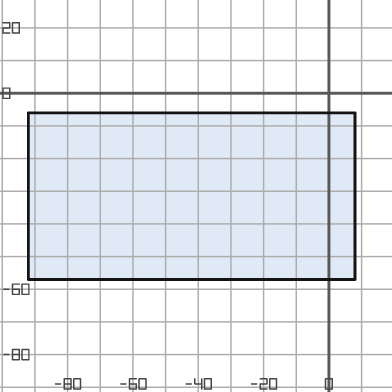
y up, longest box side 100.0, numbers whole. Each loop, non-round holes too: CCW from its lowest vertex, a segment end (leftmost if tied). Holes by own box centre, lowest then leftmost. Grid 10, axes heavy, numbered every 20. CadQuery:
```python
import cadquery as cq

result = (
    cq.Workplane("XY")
    .moveTo(-92.0, -57.0)
    .lineTo(8.0, -57.0)
    .lineTo(8.0, -6.0)
    .lineTo(-92.0, -6.0)
    .close()
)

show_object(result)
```